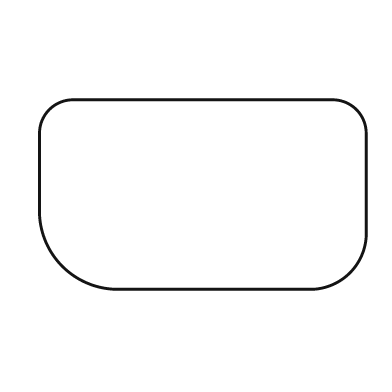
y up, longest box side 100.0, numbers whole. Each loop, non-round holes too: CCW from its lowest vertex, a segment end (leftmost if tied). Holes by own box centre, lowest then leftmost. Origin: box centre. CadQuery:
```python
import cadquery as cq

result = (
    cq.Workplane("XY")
    .moveTo(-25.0, -29.0)
    .lineTo(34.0, -29.0)
    .threePointArc((45.0, -24.0), (50.0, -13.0))
    .lineTo(50.0, 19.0)
    .threePointArc((47.0, 26.0), (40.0, 29.0))
    .lineTo(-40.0, 29.0)
    .threePointArc((-47.0, 26.0), (-50.0, 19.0))
    .lineTo(-50.0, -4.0)
    .threePointArc((-43.0, -22.0), (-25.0, -29.0))
    .close()
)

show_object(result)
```